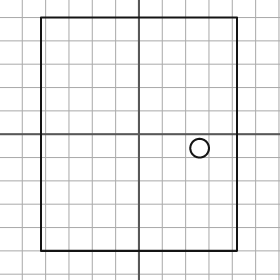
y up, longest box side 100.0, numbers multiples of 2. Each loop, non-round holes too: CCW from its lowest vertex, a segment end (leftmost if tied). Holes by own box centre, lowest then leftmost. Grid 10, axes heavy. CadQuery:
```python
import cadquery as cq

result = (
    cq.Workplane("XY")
    .moveTo(-42.0, -50.0)
    .lineTo(42.0, -50.0)
    .lineTo(42.0, 50.0)
    .lineTo(-42.0, 50.0)
    .close()
    .moveTo(26.0, -6.0)
    .circle(4.0)
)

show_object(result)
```